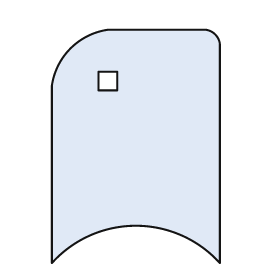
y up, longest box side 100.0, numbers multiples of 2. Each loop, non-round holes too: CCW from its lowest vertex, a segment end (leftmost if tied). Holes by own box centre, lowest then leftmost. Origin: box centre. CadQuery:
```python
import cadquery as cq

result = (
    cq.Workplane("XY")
    .moveTo(-36.0, -50.0)
    .threePointArc((0.0, -34.0), (36.0, -50.0))
    .lineTo(36.0, 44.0)
    .threePointArc((34.0, 48.0), (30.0, 50.0))
    .lineTo(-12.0, 50.0)
    .threePointArc((-28.0, 42.0), (-36.0, 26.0))
    .close()
    .moveTo(-16.0, 24.0)
    .lineTo(-8.0, 24.0)
    .lineTo(-8.0, 32.0)
    .lineTo(-16.0, 32.0)
    .close()
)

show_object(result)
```